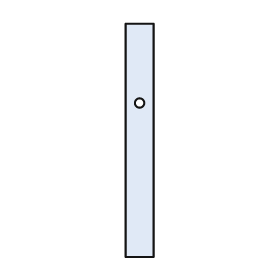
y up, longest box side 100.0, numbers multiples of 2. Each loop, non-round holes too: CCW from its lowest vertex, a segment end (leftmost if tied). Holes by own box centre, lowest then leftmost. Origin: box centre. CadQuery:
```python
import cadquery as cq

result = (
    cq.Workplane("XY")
    .moveTo(-6.0, -50.0)
    .lineTo(6.0, -50.0)
    .lineTo(6.0, 50.0)
    .lineTo(-6.0, 50.0)
    .close()
    .moveTo(0.0, 16.0)
    .circle(2.0)
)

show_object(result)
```